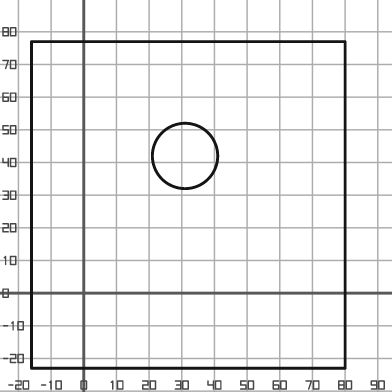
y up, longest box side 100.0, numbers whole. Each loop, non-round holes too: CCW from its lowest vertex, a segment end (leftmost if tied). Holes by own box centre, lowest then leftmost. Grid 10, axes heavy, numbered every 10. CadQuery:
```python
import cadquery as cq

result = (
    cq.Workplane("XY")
    .moveTo(-16.0, -23.0)
    .lineTo(80.0, -23.0)
    .lineTo(80.0, 77.0)
    .lineTo(-16.0, 77.0)
    .close()
    .moveTo(31.0, 42.0)
    .circle(10.0)
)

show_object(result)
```